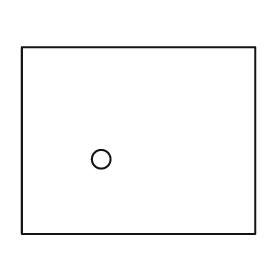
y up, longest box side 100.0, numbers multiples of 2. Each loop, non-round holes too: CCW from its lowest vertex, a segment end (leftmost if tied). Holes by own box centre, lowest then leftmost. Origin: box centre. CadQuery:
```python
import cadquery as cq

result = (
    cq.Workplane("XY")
    .moveTo(-50.0, -40.0)
    .lineTo(50.0, -40.0)
    .lineTo(50.0, 40.0)
    .lineTo(-50.0, 40.0)
    .close()
    .moveTo(-16.0, -8.0)
    .circle(4.0)
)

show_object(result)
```